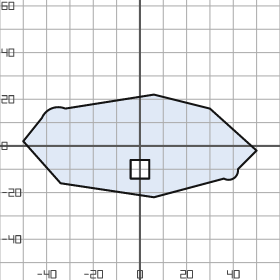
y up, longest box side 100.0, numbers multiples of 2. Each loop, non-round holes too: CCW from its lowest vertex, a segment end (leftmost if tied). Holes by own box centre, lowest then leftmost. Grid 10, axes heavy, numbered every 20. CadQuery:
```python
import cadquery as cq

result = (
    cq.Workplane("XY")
    .moveTo(6.0, -22.0)
    .lineTo(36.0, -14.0)
    .threePointArc((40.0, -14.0), (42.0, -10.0))
    .lineTo(50.0, -2.0)
    .lineTo(30.0, 16.0)
    .lineTo(6.0, 22.0)
    .lineTo(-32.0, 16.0)
    .threePointArc((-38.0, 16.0), (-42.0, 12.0))
    .lineTo(-50.0, 2.0)
    .lineTo(-34.0, -16.0)
    .close()
    .moveTo(-4.0, -14.0)
    .lineTo(4.0, -14.0)
    .lineTo(4.0, -6.0)
    .lineTo(-4.0, -6.0)
    .close()
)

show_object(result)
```